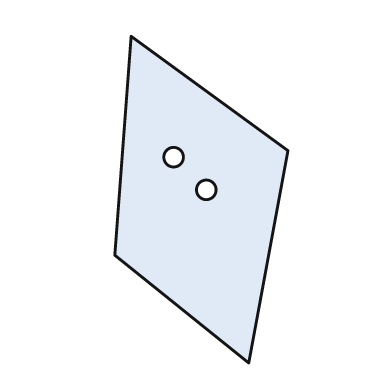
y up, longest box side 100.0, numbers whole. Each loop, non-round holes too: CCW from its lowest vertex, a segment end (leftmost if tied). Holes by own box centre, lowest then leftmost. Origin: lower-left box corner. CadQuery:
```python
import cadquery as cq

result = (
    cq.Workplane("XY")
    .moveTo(41.0, 0.0)
    .lineTo(53.0, 65.0)
    .lineTo(5.0, 100.0)
    .lineTo(0.0, 33.0)
    .close()
    .moveTo(28.0, 53.0)
    .circle(3.0)
    .moveTo(18.0, 63.0)
    .circle(3.0)
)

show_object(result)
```